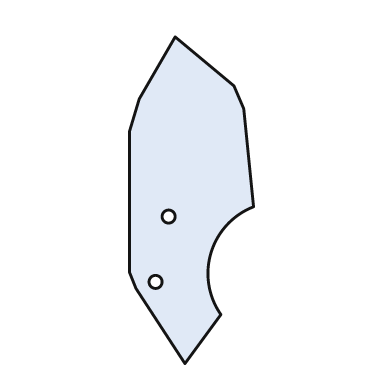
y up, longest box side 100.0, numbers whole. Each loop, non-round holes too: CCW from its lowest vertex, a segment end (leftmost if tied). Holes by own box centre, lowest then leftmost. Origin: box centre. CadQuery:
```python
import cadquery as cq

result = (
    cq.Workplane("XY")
    .moveTo(-2.0, -50.0)
    .lineTo(9.0, -35.0)
    .threePointArc((6.0, -16.0), (19.0, -2.0))
    .lineTo(16.0, 28.0)
    .lineTo(13.0, 35.0)
    .lineTo(-5.0, 50.0)
    .lineTo(-16.0, 31.0)
    .lineTo(-19.0, 21.0)
    .lineTo(-19.0, -22.0)
    .lineTo(-17.0, -27.0)
    .close()
    .moveTo(-11.0, -25.0)
    .circle(2.0)
    .moveTo(-7.0, -5.0)
    .circle(2.0)
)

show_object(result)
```